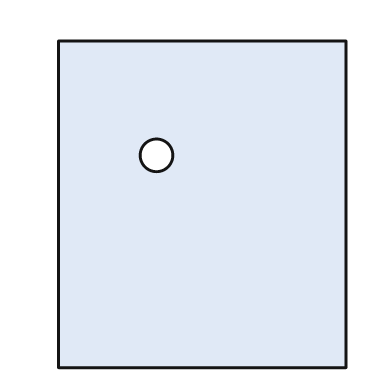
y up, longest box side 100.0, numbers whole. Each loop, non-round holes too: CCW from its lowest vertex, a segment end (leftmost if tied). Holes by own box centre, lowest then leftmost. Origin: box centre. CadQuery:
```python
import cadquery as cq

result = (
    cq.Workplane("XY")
    .moveTo(-44.0, -50.0)
    .lineTo(44.0, -50.0)
    .lineTo(44.0, 50.0)
    .lineTo(-44.0, 50.0)
    .close()
    .moveTo(-14.0, 15.0)
    .circle(5.0)
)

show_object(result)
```